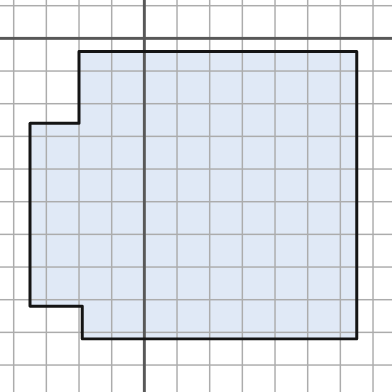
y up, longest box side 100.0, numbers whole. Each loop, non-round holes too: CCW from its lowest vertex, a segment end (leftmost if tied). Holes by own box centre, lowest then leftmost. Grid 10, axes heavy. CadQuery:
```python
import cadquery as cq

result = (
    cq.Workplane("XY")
    .moveTo(-19.0, -92.0)
    .lineTo(65.0, -92.0)
    .lineTo(65.0, -4.0)
    .lineTo(-20.0, -4.0)
    .lineTo(-20.0, -26.0)
    .lineTo(-35.0, -26.0)
    .lineTo(-35.0, -82.0)
    .lineTo(-19.0, -82.0)
    .close()
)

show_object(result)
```